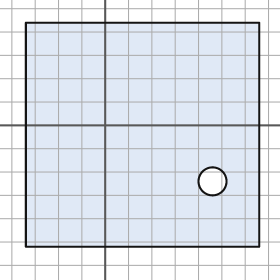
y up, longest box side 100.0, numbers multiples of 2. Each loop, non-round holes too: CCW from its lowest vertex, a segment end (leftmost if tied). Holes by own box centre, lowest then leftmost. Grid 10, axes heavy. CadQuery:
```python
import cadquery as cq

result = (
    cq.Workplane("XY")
    .moveTo(-34.0, -52.0)
    .lineTo(66.0, -52.0)
    .lineTo(66.0, 44.0)
    .lineTo(-34.0, 44.0)
    .close()
    .moveTo(46.0, -24.0)
    .circle(6.0)
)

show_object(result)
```